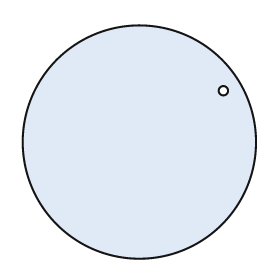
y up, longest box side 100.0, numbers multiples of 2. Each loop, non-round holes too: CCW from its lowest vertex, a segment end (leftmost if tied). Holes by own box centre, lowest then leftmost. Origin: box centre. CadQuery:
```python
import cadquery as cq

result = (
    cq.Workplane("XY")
    .moveTo(0.0, 0.0)
    .circle(50.0)
    .moveTo(36.0, 22.0)
    .circle(2.0)
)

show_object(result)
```